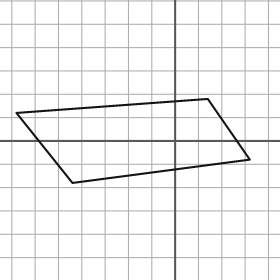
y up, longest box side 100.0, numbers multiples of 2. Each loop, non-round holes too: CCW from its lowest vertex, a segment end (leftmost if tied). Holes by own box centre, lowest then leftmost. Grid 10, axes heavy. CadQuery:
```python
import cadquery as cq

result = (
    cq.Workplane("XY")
    .moveTo(-44.0, -18.0)
    .lineTo(32.0, -8.0)
    .lineTo(14.0, 18.0)
    .lineTo(-68.0, 12.0)
    .close()
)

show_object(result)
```